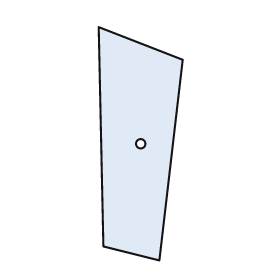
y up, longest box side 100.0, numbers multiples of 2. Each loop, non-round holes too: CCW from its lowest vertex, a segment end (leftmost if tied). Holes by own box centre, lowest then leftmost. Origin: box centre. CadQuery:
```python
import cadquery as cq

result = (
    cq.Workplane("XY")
    .moveTo(8.0, -50.0)
    .lineTo(18.0, 36.0)
    .lineTo(-18.0, 50.0)
    .lineTo(-16.0, -44.0)
    .close()
    .moveTo(0.0, 0.0)
    .circle(2.0)
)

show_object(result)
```